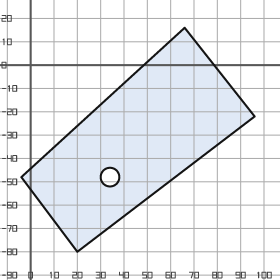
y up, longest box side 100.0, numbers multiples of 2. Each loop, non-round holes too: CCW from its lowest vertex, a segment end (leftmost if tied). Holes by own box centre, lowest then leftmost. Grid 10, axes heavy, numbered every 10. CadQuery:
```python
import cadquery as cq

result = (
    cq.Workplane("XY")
    .moveTo(20.0, -80.0)
    .lineTo(96.0, -22.0)
    .lineTo(66.0, 16.0)
    .lineTo(-4.0, -48.0)
    .close()
    .moveTo(34.0, -48.0)
    .circle(4.0)
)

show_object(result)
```